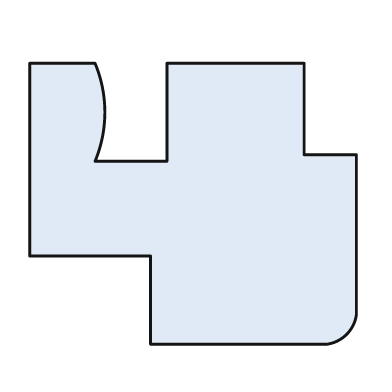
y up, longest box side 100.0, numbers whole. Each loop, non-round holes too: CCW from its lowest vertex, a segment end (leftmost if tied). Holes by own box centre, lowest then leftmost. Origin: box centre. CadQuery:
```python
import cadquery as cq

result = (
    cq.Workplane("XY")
    .moveTo(-13.0, -43.0)
    .lineTo(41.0, -43.0)
    .threePointArc((47.0, -40.0), (50.0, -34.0))
    .lineTo(50.0, 15.0)
    .lineTo(34.0, 15.0)
    .lineTo(34.0, 43.0)
    .lineTo(-8.0, 43.0)
    .lineTo(-8.0, 13.0)
    .lineTo(-30.0, 13.0)
    .threePointArc((-27.0, 28.0), (-30.0, 43.0))
    .lineTo(-50.0, 43.0)
    .lineTo(-50.0, -16.0)
    .lineTo(-13.0, -16.0)
    .close()
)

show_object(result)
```